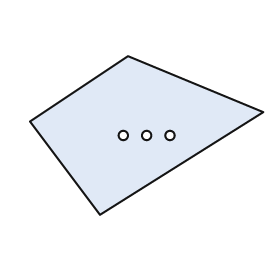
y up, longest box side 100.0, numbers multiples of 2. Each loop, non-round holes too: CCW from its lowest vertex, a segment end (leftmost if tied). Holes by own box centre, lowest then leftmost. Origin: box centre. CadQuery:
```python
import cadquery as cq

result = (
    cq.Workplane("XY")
    .moveTo(-20.0, -34.0)
    .lineTo(50.0, 10.0)
    .lineTo(-8.0, 34.0)
    .lineTo(-50.0, 6.0)
    .close()
    .moveTo(-10.0, 0.0)
    .circle(2.0)
    .moveTo(0.0, 0.0)
    .circle(2.0)
    .moveTo(10.0, 0.0)
    .circle(2.0)
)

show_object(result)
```